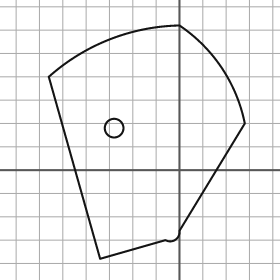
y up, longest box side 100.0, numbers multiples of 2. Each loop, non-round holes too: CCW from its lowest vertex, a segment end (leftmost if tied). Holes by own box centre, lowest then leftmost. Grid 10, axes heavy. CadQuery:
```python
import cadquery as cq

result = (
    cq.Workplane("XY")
    .moveTo(-34.0, -38.0)
    .lineTo(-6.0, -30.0)
    .threePointArc((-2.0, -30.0), (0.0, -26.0))
    .lineTo(28.0, 20.0)
    .threePointArc((18.0, 44.0), (0.0, 62.0))
    .threePointArc((-30.0, 56.0), (-56.0, 40.0))
    .close()
    .moveTo(-28.0, 18.0)
    .circle(4.0)
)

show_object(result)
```